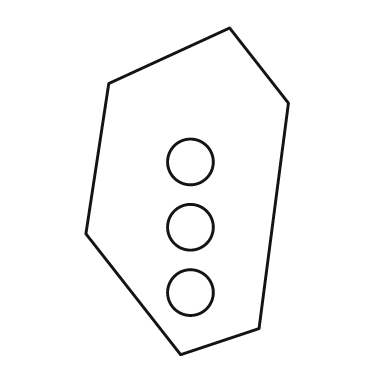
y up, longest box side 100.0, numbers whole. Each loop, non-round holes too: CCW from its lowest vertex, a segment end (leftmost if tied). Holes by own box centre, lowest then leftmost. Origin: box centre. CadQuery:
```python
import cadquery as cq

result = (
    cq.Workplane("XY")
    .moveTo(-2.0, -50.0)
    .lineTo(22.0, -42.0)
    .lineTo(31.0, 27.0)
    .lineTo(13.0, 50.0)
    .lineTo(-24.0, 33.0)
    .lineTo(-31.0, -13.0)
    .close()
    .moveTo(1.0, -31.0)
    .circle(7.0)
    .moveTo(1.0, -11.0)
    .circle(7.0)
    .moveTo(1.0, 9.0)
    .circle(7.0)
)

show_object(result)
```